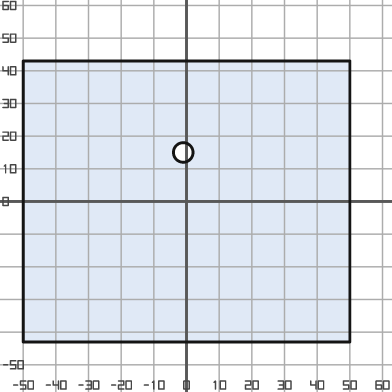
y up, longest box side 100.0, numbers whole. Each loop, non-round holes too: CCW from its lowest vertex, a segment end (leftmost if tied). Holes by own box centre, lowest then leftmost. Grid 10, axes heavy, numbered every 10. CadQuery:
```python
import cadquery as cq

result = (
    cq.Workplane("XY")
    .moveTo(-50.0, -43.0)
    .lineTo(50.0, -43.0)
    .lineTo(50.0, 43.0)
    .lineTo(-50.0, 43.0)
    .close()
    .moveTo(-1.0, 15.0)
    .circle(3.0)
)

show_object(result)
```